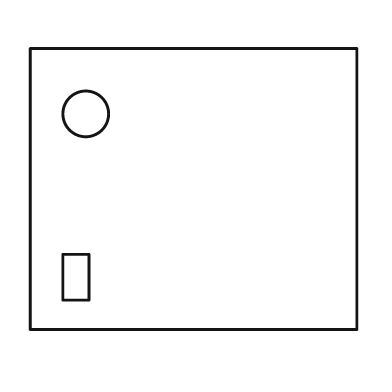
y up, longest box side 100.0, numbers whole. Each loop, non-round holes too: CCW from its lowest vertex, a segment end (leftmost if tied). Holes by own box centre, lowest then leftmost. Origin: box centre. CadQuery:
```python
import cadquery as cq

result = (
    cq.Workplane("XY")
    .moveTo(-50.0, -43.0)
    .lineTo(50.0, -43.0)
    .lineTo(50.0, 43.0)
    .lineTo(-50.0, 43.0)
    .close()
    .moveTo(-40.0, -34.0)
    .lineTo(-32.0, -34.0)
    .lineTo(-32.0, -20.0)
    .lineTo(-40.0, -20.0)
    .close()
    .moveTo(-33.0, 23.0)
    .circle(7.0)
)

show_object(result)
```